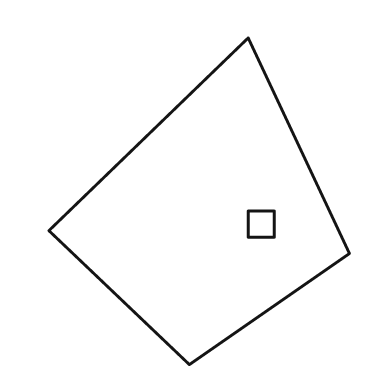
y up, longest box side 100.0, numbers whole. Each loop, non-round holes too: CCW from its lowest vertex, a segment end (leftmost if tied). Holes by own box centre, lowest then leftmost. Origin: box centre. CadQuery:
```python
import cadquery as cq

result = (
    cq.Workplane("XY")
    .moveTo(-3.0, -50.0)
    .lineTo(46.0, -16.0)
    .lineTo(15.0, 50.0)
    .lineTo(-46.0, -9.0)
    .close()
    .moveTo(15.0, -11.0)
    .lineTo(23.0, -11.0)
    .lineTo(23.0, -3.0)
    .lineTo(15.0, -3.0)
    .close()
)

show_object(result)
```